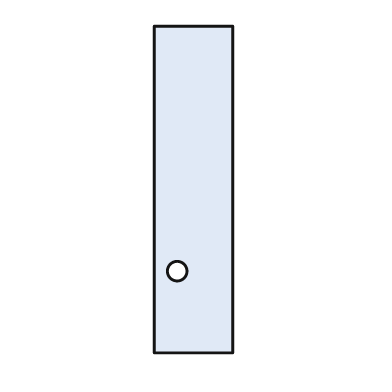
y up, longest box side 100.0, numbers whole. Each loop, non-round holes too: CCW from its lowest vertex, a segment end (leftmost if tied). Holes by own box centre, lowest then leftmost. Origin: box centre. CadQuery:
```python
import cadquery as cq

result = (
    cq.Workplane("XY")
    .moveTo(-12.0, -50.0)
    .lineTo(12.0, -50.0)
    .lineTo(12.0, 50.0)
    .lineTo(-12.0, 50.0)
    .close()
    .moveTo(-5.0, -25.0)
    .circle(3.0)
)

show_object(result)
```